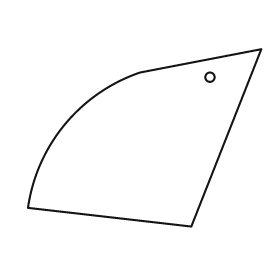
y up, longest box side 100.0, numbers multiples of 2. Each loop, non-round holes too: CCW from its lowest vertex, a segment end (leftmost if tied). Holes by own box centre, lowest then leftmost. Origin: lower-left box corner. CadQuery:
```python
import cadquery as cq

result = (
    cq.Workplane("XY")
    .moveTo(70.0, 0.0)
    .lineTo(100.0, 76.0)
    .lineTo(48.0, 66.0)
    .threePointArc((16.0, 44.0), (0.0, 8.0))
    .close()
    .moveTo(78.0, 64.0)
    .circle(2.0)
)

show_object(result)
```